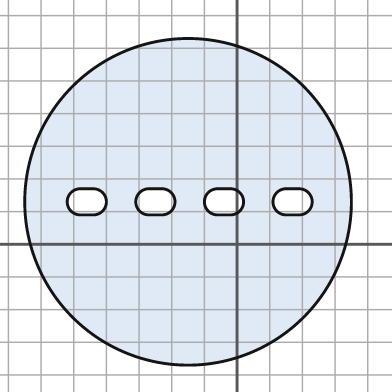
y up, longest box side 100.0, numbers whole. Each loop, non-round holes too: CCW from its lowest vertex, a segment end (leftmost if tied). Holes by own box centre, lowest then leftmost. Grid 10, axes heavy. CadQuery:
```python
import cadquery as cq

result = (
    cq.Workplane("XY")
    .moveTo(-15.0, 13.0)
    .circle(50.0)
    .moveTo(-48.0, 9.0)
    .lineTo(-44.0, 9.0)
    .threePointArc((-40.0, 13.0), (-44.0, 17.0))
    .lineTo(-48.0, 17.0)
    .threePointArc((-52.0, 13.0), (-48.0, 9.0))
    .close()
    .moveTo(-27.0, 9.0)
    .lineTo(-23.0, 9.0)
    .threePointArc((-19.0, 13.0), (-23.0, 17.0))
    .lineTo(-27.0, 17.0)
    .threePointArc((-31.0, 13.0), (-27.0, 9.0))
    .close()
    .moveTo(-6.0, 9.0)
    .lineTo(-2.0, 9.0)
    .threePointArc((2.0, 13.0), (-2.0, 17.0))
    .lineTo(-6.0, 17.0)
    .threePointArc((-10.0, 13.0), (-6.0, 9.0))
    .close()
    .moveTo(15.0, 9.0)
    .lineTo(19.0, 9.0)
    .threePointArc((23.0, 13.0), (19.0, 17.0))
    .lineTo(15.0, 17.0)
    .threePointArc((11.0, 13.0), (15.0, 9.0))
    .close()
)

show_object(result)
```